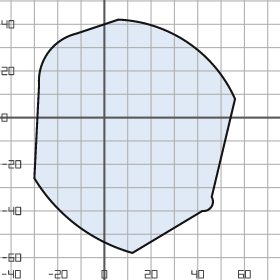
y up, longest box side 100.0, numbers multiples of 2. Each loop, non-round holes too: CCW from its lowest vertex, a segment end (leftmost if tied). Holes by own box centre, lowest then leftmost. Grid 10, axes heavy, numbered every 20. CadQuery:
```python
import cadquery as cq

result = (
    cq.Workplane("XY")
    .moveTo(12.0, -58.0)
    .lineTo(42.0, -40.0)
    .threePointArc((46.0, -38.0), (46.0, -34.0))
    .lineTo(56.0, 8.0)
    .threePointArc((36.0, 32.0), (6.0, 42.0))
    .lineTo(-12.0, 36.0)
    .threePointArc((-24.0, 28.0), (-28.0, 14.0))
    .lineTo(-30.0, -26.0)
    .threePointArc((-12.0, -46.0), (12.0, -58.0))
    .close()
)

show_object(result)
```